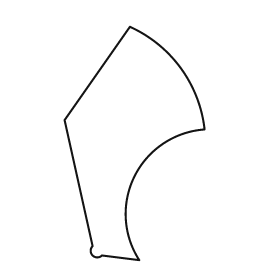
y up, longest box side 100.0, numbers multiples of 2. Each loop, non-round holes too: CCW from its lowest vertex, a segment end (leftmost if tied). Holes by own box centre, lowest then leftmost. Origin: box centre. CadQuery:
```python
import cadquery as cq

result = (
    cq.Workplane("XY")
    .moveTo(2.0, -50.0)
    .threePointArc((0.0, -14.0), (30.0, 6.0))
    .threePointArc((20.0, 32.0), (-2.0, 50.0))
    .lineTo(-30.0, 10.0)
    .lineTo(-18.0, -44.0)
    .threePointArc((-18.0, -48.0), (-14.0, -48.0))
    .close()
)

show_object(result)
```